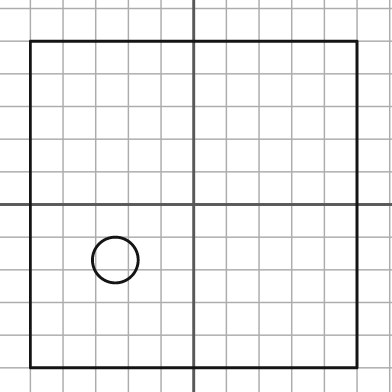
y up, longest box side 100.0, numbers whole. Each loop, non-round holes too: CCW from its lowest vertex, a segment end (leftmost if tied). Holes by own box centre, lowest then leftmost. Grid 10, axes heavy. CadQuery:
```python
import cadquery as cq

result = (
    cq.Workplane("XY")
    .moveTo(-50.0, -50.0)
    .lineTo(50.0, -50.0)
    .lineTo(50.0, 50.0)
    .lineTo(-50.0, 50.0)
    .close()
    .moveTo(-24.0, -17.0)
    .circle(7.0)
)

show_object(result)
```